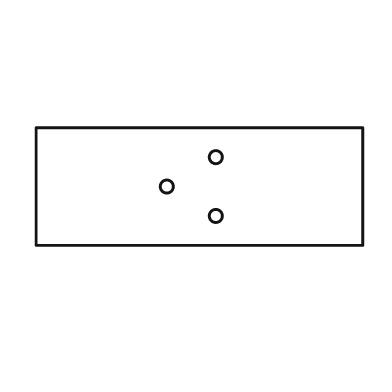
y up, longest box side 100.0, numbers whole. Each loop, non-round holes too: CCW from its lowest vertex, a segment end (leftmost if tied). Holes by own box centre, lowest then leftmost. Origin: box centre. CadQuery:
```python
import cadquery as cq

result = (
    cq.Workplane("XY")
    .moveTo(-50.0, -18.0)
    .lineTo(50.0, -18.0)
    .lineTo(50.0, 18.0)
    .lineTo(-50.0, 18.0)
    .close()
    .moveTo(5.0, -9.0)
    .circle(2.0)
    .moveTo(-10.0, 0.0)
    .circle(2.0)
    .moveTo(5.0, 9.0)
    .circle(2.0)
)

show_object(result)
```